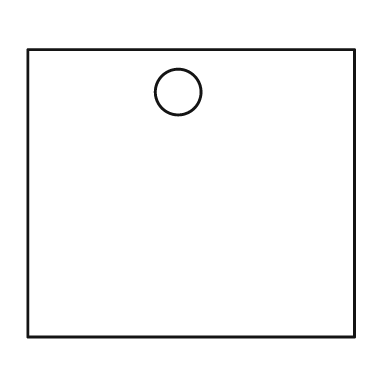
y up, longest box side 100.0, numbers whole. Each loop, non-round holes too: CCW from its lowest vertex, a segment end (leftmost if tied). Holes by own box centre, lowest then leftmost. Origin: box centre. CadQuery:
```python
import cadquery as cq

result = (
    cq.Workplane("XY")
    .moveTo(-50.0, -44.0)
    .lineTo(50.0, -44.0)
    .lineTo(50.0, 44.0)
    .lineTo(-50.0, 44.0)
    .close()
    .moveTo(-4.0, 31.0)
    .circle(7.0)
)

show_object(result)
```